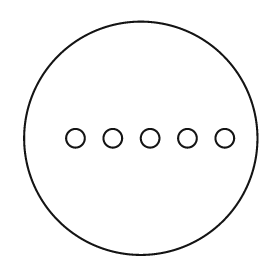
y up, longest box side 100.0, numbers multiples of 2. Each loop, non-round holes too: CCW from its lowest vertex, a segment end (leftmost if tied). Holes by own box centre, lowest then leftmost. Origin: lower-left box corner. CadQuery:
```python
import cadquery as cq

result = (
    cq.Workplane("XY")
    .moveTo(50.0, 50.0)
    .circle(50.0)
    .moveTo(22.0, 50.0)
    .circle(4.0)
    .moveTo(38.0, 50.0)
    .circle(4.0)
    .moveTo(54.0, 50.0)
    .circle(4.0)
    .moveTo(70.0, 50.0)
    .circle(4.0)
    .moveTo(86.0, 50.0)
    .circle(4.0)
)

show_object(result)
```